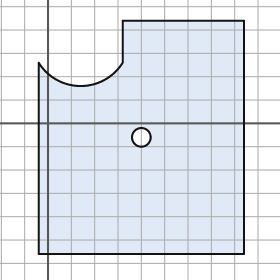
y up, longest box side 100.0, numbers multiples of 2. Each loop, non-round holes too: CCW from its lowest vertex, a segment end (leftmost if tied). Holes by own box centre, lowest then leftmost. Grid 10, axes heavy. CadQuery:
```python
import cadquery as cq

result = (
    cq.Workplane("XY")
    .moveTo(-4.0, -56.0)
    .lineTo(84.0, -56.0)
    .lineTo(84.0, 44.0)
    .lineTo(32.0, 44.0)
    .lineTo(32.0, 26.0)
    .threePointArc((14.0, 16.0), (-4.0, 26.0))
    .close()
    .moveTo(40.0, -6.0)
    .circle(4.0)
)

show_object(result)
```